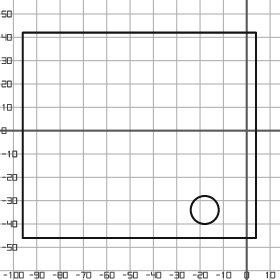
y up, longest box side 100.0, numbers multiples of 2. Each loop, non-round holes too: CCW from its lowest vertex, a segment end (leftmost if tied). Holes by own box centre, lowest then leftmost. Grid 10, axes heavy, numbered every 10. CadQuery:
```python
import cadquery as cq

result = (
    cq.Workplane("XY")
    .moveTo(-96.0, -46.0)
    .lineTo(4.0, -46.0)
    .lineTo(4.0, 42.0)
    .lineTo(-96.0, 42.0)
    .close()
    .moveTo(-18.0, -34.0)
    .circle(6.0)
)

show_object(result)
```